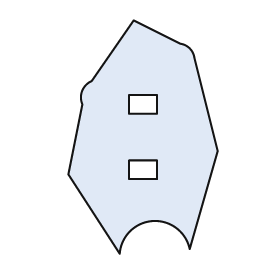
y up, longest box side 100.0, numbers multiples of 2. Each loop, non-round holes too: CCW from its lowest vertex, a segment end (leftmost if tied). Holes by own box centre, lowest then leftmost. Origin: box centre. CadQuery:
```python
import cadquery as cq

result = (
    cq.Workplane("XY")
    .moveTo(-10.0, -50.0)
    .threePointArc((4.0, -36.0), (20.0, -48.0))
    .lineTo(32.0, -6.0)
    .lineTo(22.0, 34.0)
    .threePointArc((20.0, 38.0), (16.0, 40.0))
    .lineTo(-4.0, 50.0)
    .lineTo(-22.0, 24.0)
    .threePointArc((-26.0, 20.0), (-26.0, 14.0))
    .lineTo(-32.0, -16.0)
    .close()
    .moveTo(-6.0, -18.0)
    .lineTo(6.0, -18.0)
    .lineTo(6.0, -10.0)
    .lineTo(-6.0, -10.0)
    .close()
    .moveTo(-6.0, 10.0)
    .lineTo(6.0, 10.0)
    .lineTo(6.0, 18.0)
    .lineTo(-6.0, 18.0)
    .close()
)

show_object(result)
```